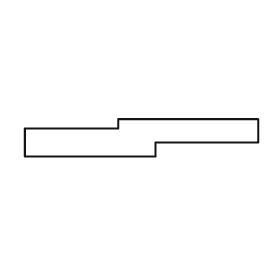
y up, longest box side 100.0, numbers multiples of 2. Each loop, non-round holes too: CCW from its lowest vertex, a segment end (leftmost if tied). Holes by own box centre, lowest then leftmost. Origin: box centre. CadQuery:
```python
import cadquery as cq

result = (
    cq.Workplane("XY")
    .moveTo(-50.0, -8.0)
    .lineTo(6.0, -8.0)
    .lineTo(6.0, -2.0)
    .lineTo(50.0, -2.0)
    .lineTo(50.0, 8.0)
    .lineTo(-10.0, 8.0)
    .lineTo(-10.0, 4.0)
    .lineTo(-50.0, 4.0)
    .close()
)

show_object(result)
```